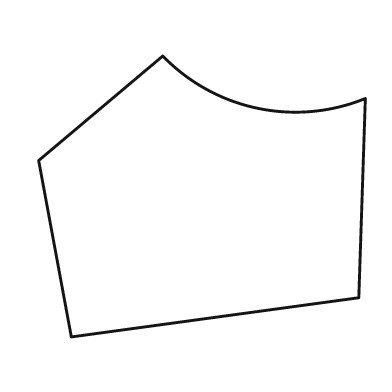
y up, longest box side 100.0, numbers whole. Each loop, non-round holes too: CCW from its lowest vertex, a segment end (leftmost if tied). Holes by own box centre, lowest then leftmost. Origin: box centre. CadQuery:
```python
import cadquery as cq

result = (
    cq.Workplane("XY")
    .moveTo(-40.0, -43.0)
    .lineTo(48.0, -31.0)
    .lineTo(50.0, 30.0)
    .threePointArc((17.0, 27.0), (-12.0, 43.0))
    .lineTo(-50.0, 11.0)
    .close()
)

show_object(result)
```